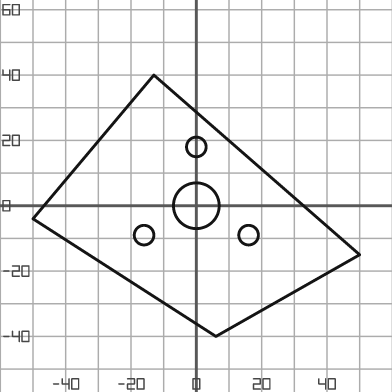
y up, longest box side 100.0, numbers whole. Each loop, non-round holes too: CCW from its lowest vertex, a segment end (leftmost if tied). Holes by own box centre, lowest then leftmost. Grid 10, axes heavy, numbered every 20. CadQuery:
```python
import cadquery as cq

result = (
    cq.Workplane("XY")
    .moveTo(6.0, -40.0)
    .lineTo(50.0, -15.0)
    .lineTo(-13.0, 40.0)
    .lineTo(-50.0, -4.0)
    .close()
    .moveTo(-16.0, -9.0)
    .circle(3.0)
    .moveTo(16.0, -9.0)
    .circle(3.0)
    .moveTo(0.0, 0.0)
    .circle(7.0)
    .moveTo(0.0, 18.0)
    .circle(3.0)
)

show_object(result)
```